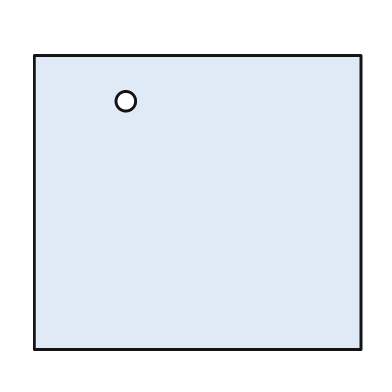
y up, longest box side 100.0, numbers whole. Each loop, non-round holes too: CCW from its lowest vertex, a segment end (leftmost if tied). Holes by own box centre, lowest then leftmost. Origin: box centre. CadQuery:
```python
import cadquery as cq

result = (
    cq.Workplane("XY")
    .moveTo(-50.0, -45.0)
    .lineTo(50.0, -45.0)
    .lineTo(50.0, 45.0)
    .lineTo(-50.0, 45.0)
    .close()
    .moveTo(-22.0, 31.0)
    .circle(3.0)
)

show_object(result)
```